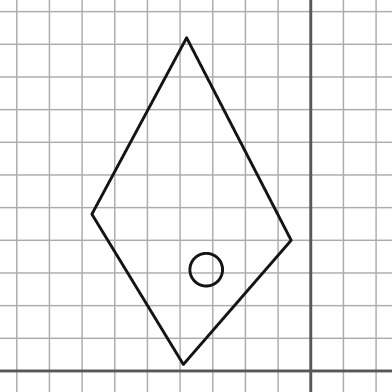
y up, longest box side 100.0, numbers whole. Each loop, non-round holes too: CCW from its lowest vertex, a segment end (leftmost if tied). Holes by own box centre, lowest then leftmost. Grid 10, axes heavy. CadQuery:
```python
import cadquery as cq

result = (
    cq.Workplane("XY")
    .moveTo(-39.0, 2.0)
    .lineTo(-6.0, 40.0)
    .lineTo(-38.0, 102.0)
    .lineTo(-67.0, 48.0)
    .close()
    .moveTo(-32.0, 31.0)
    .circle(5.0)
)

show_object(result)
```